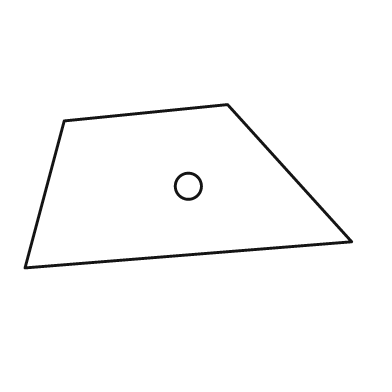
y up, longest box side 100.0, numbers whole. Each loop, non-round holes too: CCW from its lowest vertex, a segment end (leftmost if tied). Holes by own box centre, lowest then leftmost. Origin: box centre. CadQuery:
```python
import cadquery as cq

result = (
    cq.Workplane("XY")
    .moveTo(-50.0, -25.0)
    .lineTo(50.0, -17.0)
    .lineTo(12.0, 25.0)
    .lineTo(-38.0, 20.0)
    .close()
    .moveTo(0.0, 0.0)
    .circle(4.0)
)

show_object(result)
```